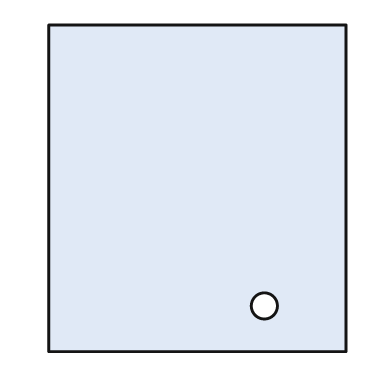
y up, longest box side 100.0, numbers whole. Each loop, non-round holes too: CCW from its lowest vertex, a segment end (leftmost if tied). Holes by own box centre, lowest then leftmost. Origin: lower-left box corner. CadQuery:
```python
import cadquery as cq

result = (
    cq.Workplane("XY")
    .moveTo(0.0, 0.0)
    .lineTo(91.0, 0.0)
    .lineTo(91.0, 100.0)
    .lineTo(0.0, 100.0)
    .close()
    .moveTo(66.0, 14.0)
    .circle(4.0)
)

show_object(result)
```